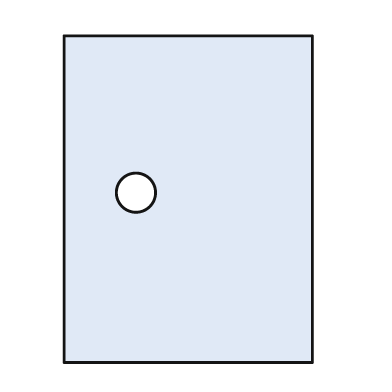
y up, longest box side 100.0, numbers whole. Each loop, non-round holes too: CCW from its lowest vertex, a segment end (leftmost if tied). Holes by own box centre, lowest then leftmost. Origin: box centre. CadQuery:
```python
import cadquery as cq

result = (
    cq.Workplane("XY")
    .moveTo(-38.0, -50.0)
    .lineTo(38.0, -50.0)
    .lineTo(38.0, 50.0)
    .lineTo(-38.0, 50.0)
    .close()
    .moveTo(-16.0, 2.0)
    .circle(6.0)
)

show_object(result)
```